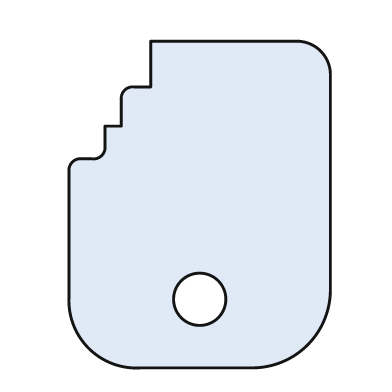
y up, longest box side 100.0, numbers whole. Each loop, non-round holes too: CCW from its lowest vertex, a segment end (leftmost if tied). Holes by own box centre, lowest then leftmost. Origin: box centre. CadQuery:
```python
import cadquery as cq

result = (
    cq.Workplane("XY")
    .moveTo(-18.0, -50.0)
    .lineTo(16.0, -50.0)
    .threePointArc((33.0, -43.0), (40.0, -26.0))
    .lineTo(40.0, 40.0)
    .threePointArc((37.0, 47.0), (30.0, 50.0))
    .lineTo(-15.0, 50.0)
    .lineTo(-15.0, 36.0)
    .lineTo(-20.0, 36.0)
    .threePointArc((-23.0, 35.0), (-24.0, 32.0))
    .lineTo(-24.0, 24.0)
    .lineTo(-29.0, 24.0)
    .lineTo(-29.0, 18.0)
    .threePointArc((-30.0, 15.0), (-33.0, 14.0))
    .lineTo(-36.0, 14.0)
    .threePointArc((-39.0, 13.0), (-40.0, 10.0))
    .lineTo(-40.0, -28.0)
    .threePointArc((-34.0, -44.0), (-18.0, -50.0))
    .close()
    .moveTo(0.0, -29.0)
    .circle(8.0)
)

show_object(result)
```